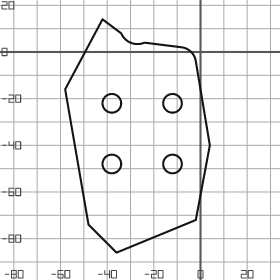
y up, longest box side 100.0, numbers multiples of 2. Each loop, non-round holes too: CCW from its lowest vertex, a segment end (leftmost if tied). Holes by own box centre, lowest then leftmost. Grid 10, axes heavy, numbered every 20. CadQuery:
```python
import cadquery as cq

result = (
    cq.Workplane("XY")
    .moveTo(-36.0, -86.0)
    .lineTo(-2.0, -72.0)
    .lineTo(4.0, -40.0)
    .lineTo(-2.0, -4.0)
    .threePointArc((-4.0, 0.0), (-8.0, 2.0))
    .lineTo(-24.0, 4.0)
    .threePointArc((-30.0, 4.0), (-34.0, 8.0))
    .lineTo(-42.0, 14.0)
    .lineTo(-58.0, -16.0)
    .lineTo(-48.0, -74.0)
    .close()
    .moveTo(-38.0, -48.0)
    .circle(4.0)
    .moveTo(-12.0, -48.0)
    .circle(4.0)
    .moveTo(-38.0, -22.0)
    .circle(4.0)
    .moveTo(-12.0, -22.0)
    .circle(4.0)
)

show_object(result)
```